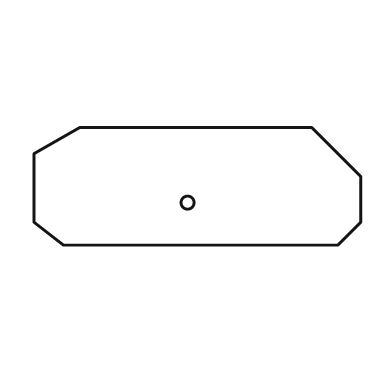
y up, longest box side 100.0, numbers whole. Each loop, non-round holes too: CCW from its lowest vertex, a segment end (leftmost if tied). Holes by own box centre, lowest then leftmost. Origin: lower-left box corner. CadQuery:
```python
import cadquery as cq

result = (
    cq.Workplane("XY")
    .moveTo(9.0, 0.0)
    .lineTo(93.0, 0.0)
    .lineTo(100.0, 7.0)
    .lineTo(100.0, 21.0)
    .lineTo(85.0, 36.0)
    .lineTo(14.0, 36.0)
    .lineTo(0.0, 28.0)
    .lineTo(0.0, 7.0)
    .close()
    .moveTo(47.0, 13.0)
    .circle(2.0)
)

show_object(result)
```